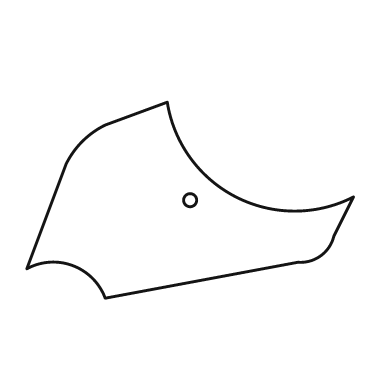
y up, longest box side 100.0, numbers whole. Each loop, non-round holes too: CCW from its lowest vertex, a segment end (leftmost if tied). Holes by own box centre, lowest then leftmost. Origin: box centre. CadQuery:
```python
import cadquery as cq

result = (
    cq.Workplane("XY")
    .moveTo(-26.0, -30.0)
    .lineTo(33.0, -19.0)
    .threePointArc((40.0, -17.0), (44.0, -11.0))
    .lineTo(50.0, 1.0)
    .threePointArc((14.0, 1.0), (-7.0, 30.0))
    .lineTo(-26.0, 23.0)
    .threePointArc((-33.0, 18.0), (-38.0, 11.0))
    .lineTo(-50.0, -21.0)
    .threePointArc((-36.0, -20.0), (-26.0, -30.0))
    .close()
    .moveTo(0.0, 0.0)
    .circle(2.0)
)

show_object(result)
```